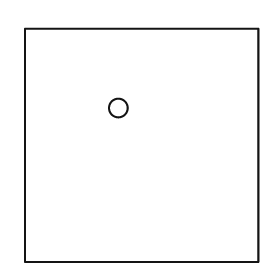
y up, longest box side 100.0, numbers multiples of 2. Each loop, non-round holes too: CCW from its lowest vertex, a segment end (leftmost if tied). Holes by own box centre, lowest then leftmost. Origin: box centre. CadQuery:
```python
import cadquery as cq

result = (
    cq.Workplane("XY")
    .moveTo(-50.0, -50.0)
    .lineTo(50.0, -50.0)
    .lineTo(50.0, 50.0)
    .lineTo(-50.0, 50.0)
    .close()
    .moveTo(-10.0, 16.0)
    .circle(4.0)
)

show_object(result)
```